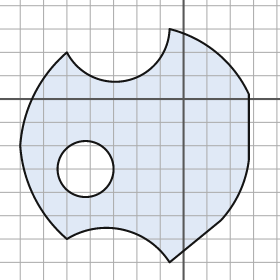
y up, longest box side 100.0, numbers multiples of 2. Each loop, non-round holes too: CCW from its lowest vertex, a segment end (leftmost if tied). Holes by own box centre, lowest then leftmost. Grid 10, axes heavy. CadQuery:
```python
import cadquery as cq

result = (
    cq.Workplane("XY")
    .moveTo(-6.0, -70.0)
    .lineTo(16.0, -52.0)
    .threePointArc((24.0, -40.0), (28.0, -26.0))
    .lineTo(28.0, 2.0)
    .threePointArc((14.0, 20.0), (-6.0, 30.0))
    .threePointArc((-24.0, 8.0), (-50.0, 20.0))
    .threePointArc((-64.0, 2.0), (-70.0, -20.0))
    .threePointArc((-64.0, -42.0), (-50.0, -60.0))
    .threePointArc((-26.0, -56.0), (-6.0, -70.0))
    .close()
    .moveTo(-42.0, -30.0)
    .circle(12.0)
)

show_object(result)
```